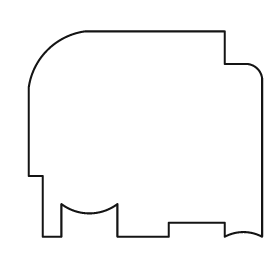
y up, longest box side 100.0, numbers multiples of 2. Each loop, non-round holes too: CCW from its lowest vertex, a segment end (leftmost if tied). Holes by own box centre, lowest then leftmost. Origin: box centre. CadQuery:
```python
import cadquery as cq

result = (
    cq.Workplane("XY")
    .moveTo(-44.0, -44.0)
    .lineTo(-36.0, -44.0)
    .lineTo(-36.0, -30.0)
    .threePointArc((-24.0, -34.0), (-12.0, -30.0))
    .lineTo(-12.0, -44.0)
    .lineTo(10.0, -44.0)
    .lineTo(10.0, -38.0)
    .lineTo(34.0, -38.0)
    .lineTo(34.0, -44.0)
    .threePointArc((42.0, -42.0), (50.0, -44.0))
    .lineTo(50.0, 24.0)
    .threePointArc((48.0, 28.0), (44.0, 30.0))
    .lineTo(34.0, 30.0)
    .lineTo(34.0, 44.0)
    .lineTo(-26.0, 44.0)
    .threePointArc((-42.0, 36.0), (-50.0, 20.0))
    .lineTo(-50.0, -18.0)
    .lineTo(-44.0, -18.0)
    .close()
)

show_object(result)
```